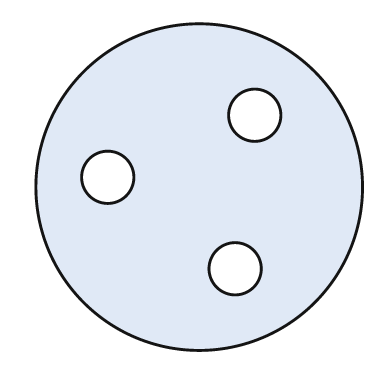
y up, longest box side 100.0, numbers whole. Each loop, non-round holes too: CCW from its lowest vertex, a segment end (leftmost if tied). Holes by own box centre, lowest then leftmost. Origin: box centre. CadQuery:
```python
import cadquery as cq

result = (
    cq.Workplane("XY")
    .moveTo(0.0, 0.0)
    .circle(50.0)
    .moveTo(11.0, -25.0)
    .circle(8.0)
    .moveTo(-28.0, 3.0)
    .circle(8.0)
    .moveTo(17.0, 22.0)
    .circle(8.0)
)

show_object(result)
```